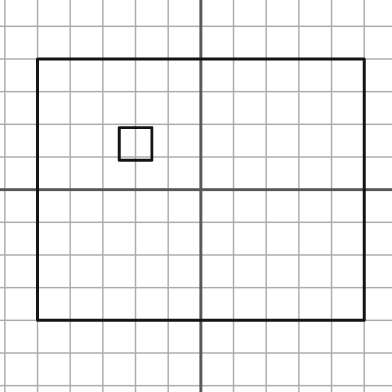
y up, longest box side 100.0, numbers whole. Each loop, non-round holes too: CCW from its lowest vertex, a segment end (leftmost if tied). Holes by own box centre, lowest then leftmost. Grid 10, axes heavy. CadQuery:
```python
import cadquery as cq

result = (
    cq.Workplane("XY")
    .moveTo(-50.0, -40.0)
    .lineTo(50.0, -40.0)
    .lineTo(50.0, 40.0)
    .lineTo(-50.0, 40.0)
    .close()
    .moveTo(-25.0, 9.0)
    .lineTo(-15.0, 9.0)
    .lineTo(-15.0, 19.0)
    .lineTo(-25.0, 19.0)
    .close()
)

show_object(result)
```